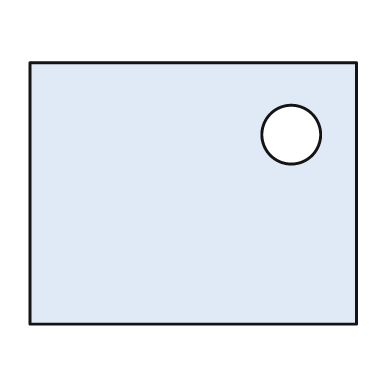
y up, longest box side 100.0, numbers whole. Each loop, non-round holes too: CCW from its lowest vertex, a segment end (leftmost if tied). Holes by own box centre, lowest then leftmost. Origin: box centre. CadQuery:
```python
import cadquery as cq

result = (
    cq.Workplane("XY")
    .moveTo(-50.0, -40.0)
    .lineTo(50.0, -40.0)
    .lineTo(50.0, 40.0)
    .lineTo(-50.0, 40.0)
    .close()
    .moveTo(30.0, 18.0)
    .circle(9.0)
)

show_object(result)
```